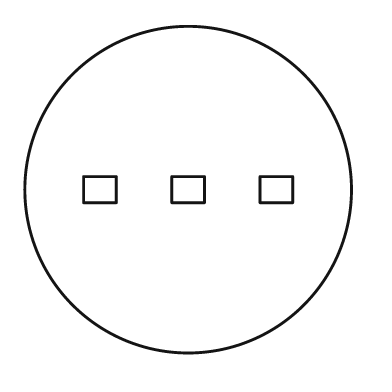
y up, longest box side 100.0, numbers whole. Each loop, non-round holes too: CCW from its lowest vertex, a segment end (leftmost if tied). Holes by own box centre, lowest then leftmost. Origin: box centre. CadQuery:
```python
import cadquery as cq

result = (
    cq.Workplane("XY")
    .moveTo(0.0, 0.0)
    .circle(50.0)
    .moveTo(-32.0, -4.0)
    .lineTo(-22.0, -4.0)
    .lineTo(-22.0, 4.0)
    .lineTo(-32.0, 4.0)
    .close()
    .moveTo(-5.0, -4.0)
    .lineTo(5.0, -4.0)
    .lineTo(5.0, 4.0)
    .lineTo(-5.0, 4.0)
    .close()
    .moveTo(22.0, -4.0)
    .lineTo(32.0, -4.0)
    .lineTo(32.0, 4.0)
    .lineTo(22.0, 4.0)
    .close()
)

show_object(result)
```